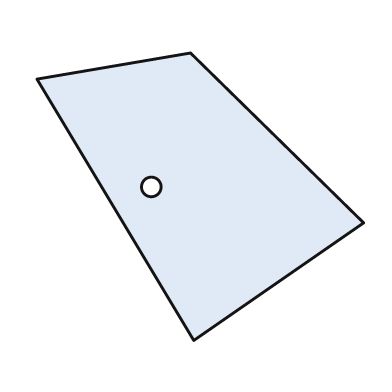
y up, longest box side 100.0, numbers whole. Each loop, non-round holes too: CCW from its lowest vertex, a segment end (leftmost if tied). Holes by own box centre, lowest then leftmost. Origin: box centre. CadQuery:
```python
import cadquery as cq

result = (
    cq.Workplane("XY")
    .moveTo(-2.0, -44.0)
    .lineTo(50.0, -8.0)
    .lineTo(-3.0, 44.0)
    .lineTo(-50.0, 36.0)
    .close()
    .moveTo(-15.0, 3.0)
    .circle(3.0)
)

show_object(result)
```